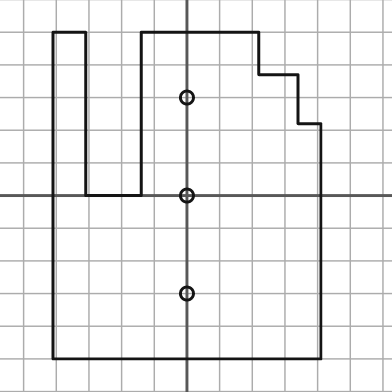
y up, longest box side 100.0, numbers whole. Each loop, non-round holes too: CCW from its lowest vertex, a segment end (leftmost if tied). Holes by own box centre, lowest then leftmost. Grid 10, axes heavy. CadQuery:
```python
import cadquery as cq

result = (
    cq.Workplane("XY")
    .moveTo(-41.0, -50.0)
    .lineTo(41.0, -50.0)
    .lineTo(41.0, 22.0)
    .lineTo(34.0, 22.0)
    .lineTo(34.0, 37.0)
    .lineTo(22.0, 37.0)
    .lineTo(22.0, 50.0)
    .lineTo(-14.0, 50.0)
    .lineTo(-14.0, 0.0)
    .lineTo(-31.0, 0.0)
    .lineTo(-31.0, 50.0)
    .lineTo(-41.0, 50.0)
    .close()
    .moveTo(0.0, -30.0)
    .circle(2.0)
    .moveTo(0.0, 0.0)
    .circle(2.0)
    .moveTo(0.0, 30.0)
    .circle(2.0)
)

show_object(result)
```